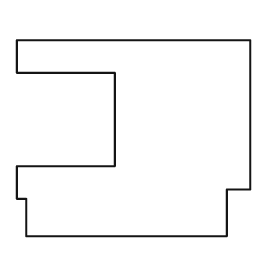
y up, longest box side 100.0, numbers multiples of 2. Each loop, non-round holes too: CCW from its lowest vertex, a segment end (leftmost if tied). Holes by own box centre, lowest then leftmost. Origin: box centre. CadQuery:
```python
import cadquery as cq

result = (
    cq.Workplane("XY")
    .moveTo(-46.0, -42.0)
    .lineTo(40.0, -42.0)
    .lineTo(40.0, -22.0)
    .lineTo(50.0, -22.0)
    .lineTo(50.0, 42.0)
    .lineTo(-50.0, 42.0)
    .lineTo(-50.0, 28.0)
    .lineTo(-8.0, 28.0)
    .lineTo(-8.0, -12.0)
    .lineTo(-50.0, -12.0)
    .lineTo(-50.0, -26.0)
    .lineTo(-46.0, -26.0)
    .close()
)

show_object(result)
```